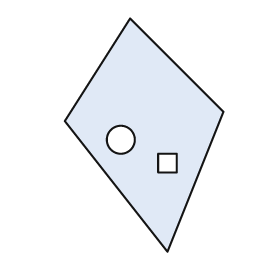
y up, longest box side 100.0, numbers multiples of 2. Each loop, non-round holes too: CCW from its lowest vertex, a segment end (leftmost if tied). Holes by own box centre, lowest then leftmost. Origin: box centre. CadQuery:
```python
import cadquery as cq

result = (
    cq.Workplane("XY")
    .moveTo(10.0, -50.0)
    .lineTo(34.0, 10.0)
    .lineTo(-6.0, 50.0)
    .lineTo(-34.0, 6.0)
    .close()
    .moveTo(6.0, -16.0)
    .lineTo(14.0, -16.0)
    .lineTo(14.0, -8.0)
    .lineTo(6.0, -8.0)
    .close()
    .moveTo(-10.0, -2.0)
    .circle(6.0)
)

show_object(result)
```